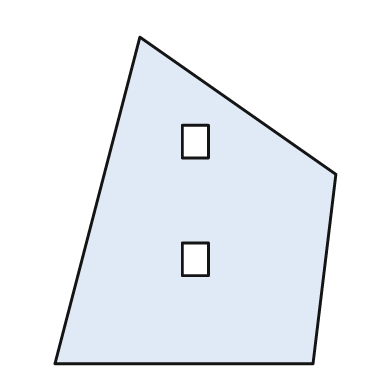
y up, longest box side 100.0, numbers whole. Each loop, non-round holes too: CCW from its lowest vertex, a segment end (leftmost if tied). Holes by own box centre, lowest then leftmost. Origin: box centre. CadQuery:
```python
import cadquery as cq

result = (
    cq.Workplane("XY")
    .moveTo(-43.0, -50.0)
    .lineTo(36.0, -50.0)
    .lineTo(43.0, 8.0)
    .lineTo(-17.0, 50.0)
    .close()
    .moveTo(-4.0, -23.0)
    .lineTo(4.0, -23.0)
    .lineTo(4.0, -13.0)
    .lineTo(-4.0, -13.0)
    .close()
    .moveTo(-4.0, 13.0)
    .lineTo(4.0, 13.0)
    .lineTo(4.0, 23.0)
    .lineTo(-4.0, 23.0)
    .close()
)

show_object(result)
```